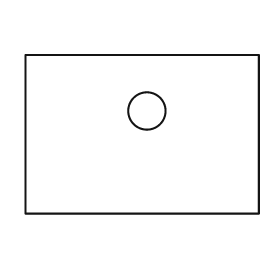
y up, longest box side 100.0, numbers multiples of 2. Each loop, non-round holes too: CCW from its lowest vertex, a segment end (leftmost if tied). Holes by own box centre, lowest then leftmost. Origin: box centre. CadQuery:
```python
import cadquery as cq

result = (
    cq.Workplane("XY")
    .moveTo(-50.0, -34.0)
    .lineTo(50.0, -34.0)
    .lineTo(50.0, 34.0)
    .lineTo(-50.0, 34.0)
    .close()
    .moveTo(2.0, 10.0)
    .circle(8.0)
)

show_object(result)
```